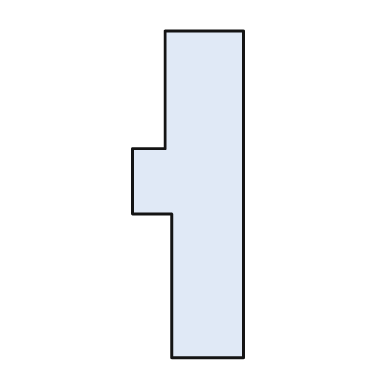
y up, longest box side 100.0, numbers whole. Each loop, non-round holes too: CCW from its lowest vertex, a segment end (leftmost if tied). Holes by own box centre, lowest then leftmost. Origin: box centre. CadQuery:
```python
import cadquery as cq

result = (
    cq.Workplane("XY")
    .moveTo(-5.0, -50.0)
    .lineTo(17.0, -50.0)
    .lineTo(17.0, 50.0)
    .lineTo(-7.0, 50.0)
    .lineTo(-7.0, 14.0)
    .lineTo(-17.0, 14.0)
    .lineTo(-17.0, -6.0)
    .lineTo(-5.0, -6.0)
    .close()
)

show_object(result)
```